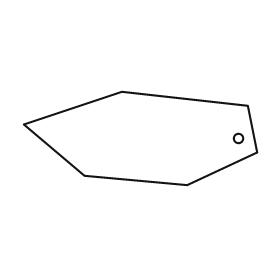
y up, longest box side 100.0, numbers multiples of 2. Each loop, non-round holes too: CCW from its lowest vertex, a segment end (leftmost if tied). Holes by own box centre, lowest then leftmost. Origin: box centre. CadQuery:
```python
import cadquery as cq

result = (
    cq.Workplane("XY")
    .moveTo(20.0, -20.0)
    .lineTo(50.0, -6.0)
    .lineTo(46.0, 14.0)
    .lineTo(-8.0, 20.0)
    .lineTo(-50.0, 6.0)
    .lineTo(-24.0, -16.0)
    .close()
    .moveTo(42.0, 0.0)
    .circle(2.0)
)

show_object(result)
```